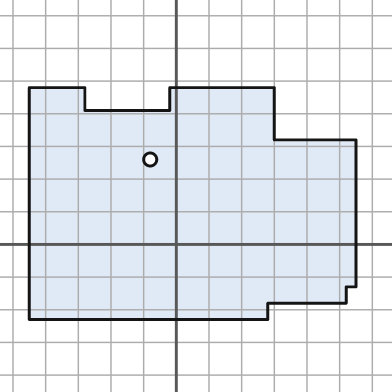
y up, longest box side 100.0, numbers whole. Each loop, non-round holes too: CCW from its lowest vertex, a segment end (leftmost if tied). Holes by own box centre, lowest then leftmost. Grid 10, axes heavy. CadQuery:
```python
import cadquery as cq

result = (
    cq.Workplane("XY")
    .moveTo(-45.0, -23.0)
    .lineTo(28.0, -23.0)
    .lineTo(28.0, -18.0)
    .lineTo(52.0, -18.0)
    .lineTo(52.0, -13.0)
    .lineTo(55.0, -13.0)
    .lineTo(55.0, 32.0)
    .lineTo(30.0, 32.0)
    .lineTo(30.0, 48.0)
    .lineTo(-2.0, 48.0)
    .lineTo(-2.0, 41.0)
    .lineTo(-28.0, 41.0)
    .lineTo(-28.0, 48.0)
    .lineTo(-45.0, 48.0)
    .close()
    .moveTo(-8.0, 26.0)
    .circle(2.0)
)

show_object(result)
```